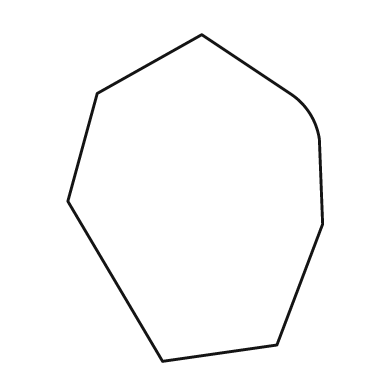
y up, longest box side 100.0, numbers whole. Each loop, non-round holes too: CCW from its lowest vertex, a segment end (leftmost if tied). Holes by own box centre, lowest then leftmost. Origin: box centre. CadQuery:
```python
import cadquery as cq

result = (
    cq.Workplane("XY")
    .moveTo(-10.0, -50.0)
    .lineTo(25.0, -45.0)
    .lineTo(39.0, -8.0)
    .lineTo(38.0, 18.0)
    .threePointArc((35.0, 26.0), (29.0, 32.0))
    .lineTo(2.0, 50.0)
    .lineTo(-30.0, 32.0)
    .lineTo(-39.0, -1.0)
    .close()
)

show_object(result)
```